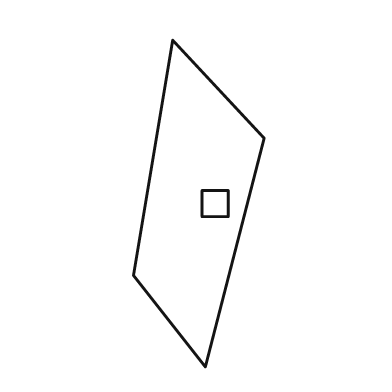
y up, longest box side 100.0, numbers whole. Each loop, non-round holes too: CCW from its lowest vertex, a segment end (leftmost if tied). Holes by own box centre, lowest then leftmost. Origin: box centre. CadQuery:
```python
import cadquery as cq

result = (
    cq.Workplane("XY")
    .moveTo(2.0, -50.0)
    .lineTo(20.0, 20.0)
    .lineTo(-8.0, 50.0)
    .lineTo(-20.0, -22.0)
    .close()
    .moveTo(1.0, -4.0)
    .lineTo(9.0, -4.0)
    .lineTo(9.0, 4.0)
    .lineTo(1.0, 4.0)
    .close()
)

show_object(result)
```